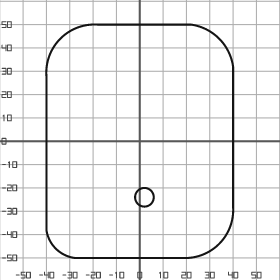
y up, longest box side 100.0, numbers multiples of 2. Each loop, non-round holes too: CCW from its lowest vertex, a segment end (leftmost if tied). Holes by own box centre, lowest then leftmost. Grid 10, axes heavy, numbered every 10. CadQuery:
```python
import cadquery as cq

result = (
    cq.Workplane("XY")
    .moveTo(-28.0, -50.0)
    .lineTo(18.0, -50.0)
    .threePointArc((34.0, -44.0), (40.0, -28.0))
    .lineTo(40.0, 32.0)
    .threePointArc((34.0, 44.0), (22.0, 50.0))
    .lineTo(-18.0, 50.0)
    .threePointArc((-34.0, 44.0), (-40.0, 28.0))
    .lineTo(-40.0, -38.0)
    .threePointArc((-36.0, -46.0), (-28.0, -50.0))
    .close()
    .moveTo(2.0, -24.0)
    .circle(4.0)
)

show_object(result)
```